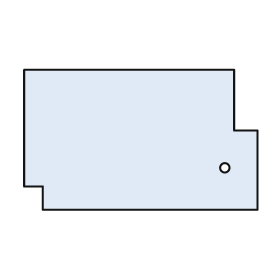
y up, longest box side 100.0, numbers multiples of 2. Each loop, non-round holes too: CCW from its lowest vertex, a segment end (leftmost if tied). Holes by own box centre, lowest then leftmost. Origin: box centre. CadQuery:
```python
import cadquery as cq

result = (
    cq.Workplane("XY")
    .moveTo(-42.0, -30.0)
    .lineTo(50.0, -30.0)
    .lineTo(50.0, 4.0)
    .lineTo(40.0, 4.0)
    .lineTo(40.0, 30.0)
    .lineTo(-50.0, 30.0)
    .lineTo(-50.0, -20.0)
    .lineTo(-42.0, -20.0)
    .close()
    .moveTo(36.0, -12.0)
    .circle(2.0)
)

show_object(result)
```